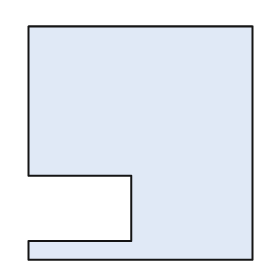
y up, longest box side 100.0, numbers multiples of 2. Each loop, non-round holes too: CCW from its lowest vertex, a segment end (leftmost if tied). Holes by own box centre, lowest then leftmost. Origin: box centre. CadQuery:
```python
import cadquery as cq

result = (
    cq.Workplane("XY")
    .moveTo(-48.0, -50.0)
    .lineTo(48.0, -50.0)
    .lineTo(48.0, 50.0)
    .lineTo(-48.0, 50.0)
    .lineTo(-48.0, -14.0)
    .lineTo(-4.0, -14.0)
    .lineTo(-4.0, -42.0)
    .lineTo(-48.0, -42.0)
    .close()
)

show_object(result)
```